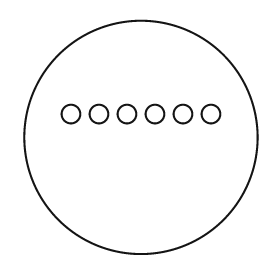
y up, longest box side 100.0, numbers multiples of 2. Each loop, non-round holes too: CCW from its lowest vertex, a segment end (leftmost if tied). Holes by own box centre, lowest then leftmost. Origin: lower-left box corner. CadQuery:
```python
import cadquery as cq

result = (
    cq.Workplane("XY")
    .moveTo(50.0, 50.0)
    .circle(50.0)
    .moveTo(20.0, 60.0)
    .circle(4.0)
    .moveTo(32.0, 60.0)
    .circle(4.0)
    .moveTo(44.0, 60.0)
    .circle(4.0)
    .moveTo(56.0, 60.0)
    .circle(4.0)
    .moveTo(68.0, 60.0)
    .circle(4.0)
    .moveTo(80.0, 60.0)
    .circle(4.0)
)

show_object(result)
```